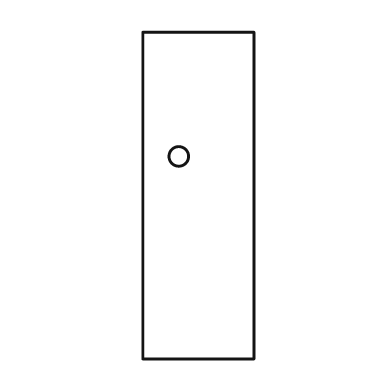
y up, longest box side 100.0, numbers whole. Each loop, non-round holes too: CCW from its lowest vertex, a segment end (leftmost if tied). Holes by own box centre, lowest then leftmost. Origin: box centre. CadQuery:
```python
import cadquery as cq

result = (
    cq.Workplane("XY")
    .moveTo(-17.0, -50.0)
    .lineTo(17.0, -50.0)
    .lineTo(17.0, 50.0)
    .lineTo(-17.0, 50.0)
    .close()
    .moveTo(-6.0, 12.0)
    .circle(3.0)
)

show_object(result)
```